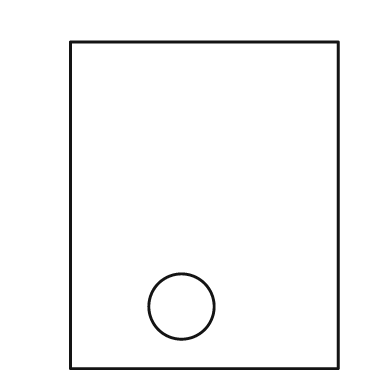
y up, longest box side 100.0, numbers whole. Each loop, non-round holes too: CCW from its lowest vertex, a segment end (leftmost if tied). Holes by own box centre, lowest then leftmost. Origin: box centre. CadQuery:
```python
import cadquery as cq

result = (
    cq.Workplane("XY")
    .moveTo(-41.0, -50.0)
    .lineTo(41.0, -50.0)
    .lineTo(41.0, 50.0)
    .lineTo(-41.0, 50.0)
    .close()
    .moveTo(-7.0, -31.0)
    .circle(10.0)
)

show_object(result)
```